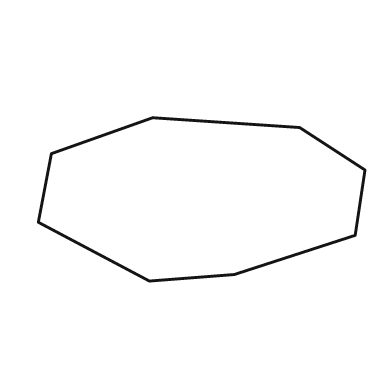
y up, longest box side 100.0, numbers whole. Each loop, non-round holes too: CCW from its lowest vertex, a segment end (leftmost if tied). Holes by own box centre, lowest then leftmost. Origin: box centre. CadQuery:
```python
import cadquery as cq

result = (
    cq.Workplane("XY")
    .moveTo(-16.0, -25.0)
    .lineTo(10.0, -23.0)
    .lineTo(47.0, -11.0)
    .lineTo(50.0, 9.0)
    .lineTo(30.0, 22.0)
    .lineTo(-15.0, 25.0)
    .lineTo(-46.0, 14.0)
    .lineTo(-50.0, -7.0)
    .close()
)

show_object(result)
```